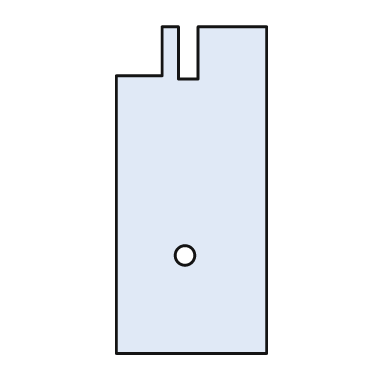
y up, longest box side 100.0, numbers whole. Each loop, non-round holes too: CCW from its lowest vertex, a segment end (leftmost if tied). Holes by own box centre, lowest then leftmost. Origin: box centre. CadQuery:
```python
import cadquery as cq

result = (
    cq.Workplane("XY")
    .moveTo(-23.0, -50.0)
    .lineTo(23.0, -50.0)
    .lineTo(23.0, 50.0)
    .lineTo(2.0, 50.0)
    .lineTo(2.0, 34.0)
    .lineTo(-4.0, 34.0)
    .lineTo(-4.0, 50.0)
    .lineTo(-9.0, 50.0)
    .lineTo(-9.0, 35.0)
    .lineTo(-23.0, 35.0)
    .close()
    .moveTo(-2.0, -20.0)
    .circle(3.0)
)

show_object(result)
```